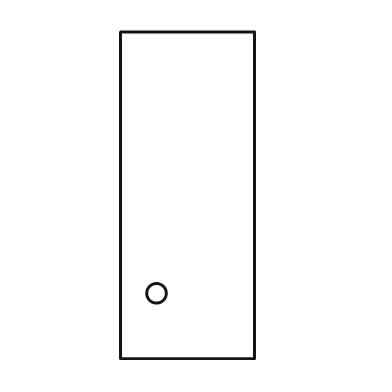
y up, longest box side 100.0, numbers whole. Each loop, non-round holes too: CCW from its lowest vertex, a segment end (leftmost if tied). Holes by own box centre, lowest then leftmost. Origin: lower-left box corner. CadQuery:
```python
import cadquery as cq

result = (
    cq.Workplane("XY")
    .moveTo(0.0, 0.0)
    .lineTo(41.0, 0.0)
    .lineTo(41.0, 100.0)
    .lineTo(0.0, 100.0)
    .close()
    .moveTo(11.0, 20.0)
    .circle(3.0)
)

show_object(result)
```